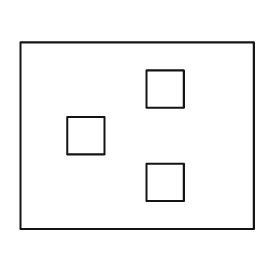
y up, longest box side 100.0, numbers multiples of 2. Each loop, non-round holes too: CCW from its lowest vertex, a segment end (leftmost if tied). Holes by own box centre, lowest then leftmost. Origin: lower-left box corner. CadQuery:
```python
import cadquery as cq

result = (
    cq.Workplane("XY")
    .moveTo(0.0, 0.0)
    .lineTo(100.0, 0.0)
    .lineTo(100.0, 80.0)
    .lineTo(0.0, 80.0)
    .close()
    .moveTo(54.0, 12.0)
    .lineTo(70.0, 12.0)
    .lineTo(70.0, 28.0)
    .lineTo(54.0, 28.0)
    .close()
    .moveTo(20.0, 32.0)
    .lineTo(36.0, 32.0)
    .lineTo(36.0, 48.0)
    .lineTo(20.0, 48.0)
    .close()
    .moveTo(54.0, 52.0)
    .lineTo(70.0, 52.0)
    .lineTo(70.0, 68.0)
    .lineTo(54.0, 68.0)
    .close()
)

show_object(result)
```